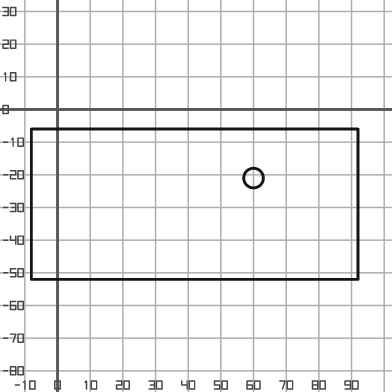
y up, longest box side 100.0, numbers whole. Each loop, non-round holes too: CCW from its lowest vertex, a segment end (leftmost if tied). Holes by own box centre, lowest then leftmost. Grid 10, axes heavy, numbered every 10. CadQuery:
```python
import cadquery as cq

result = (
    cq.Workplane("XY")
    .moveTo(-8.0, -52.0)
    .lineTo(92.0, -52.0)
    .lineTo(92.0, -6.0)
    .lineTo(-8.0, -6.0)
    .close()
    .moveTo(60.0, -21.0)
    .circle(3.0)
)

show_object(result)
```